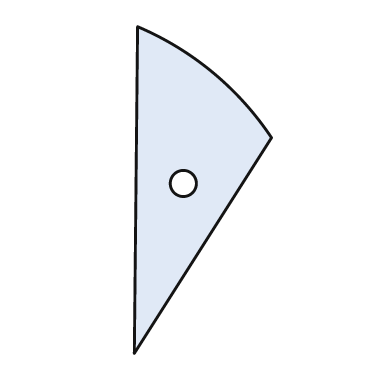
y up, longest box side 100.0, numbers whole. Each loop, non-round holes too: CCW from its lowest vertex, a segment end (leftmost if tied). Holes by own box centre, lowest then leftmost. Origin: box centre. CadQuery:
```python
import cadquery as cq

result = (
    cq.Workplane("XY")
    .moveTo(-21.0, -50.0)
    .lineTo(21.0, 16.0)
    .threePointArc((3.0, 36.0), (-20.0, 50.0))
    .close()
    .moveTo(-6.0, 2.0)
    .circle(4.0)
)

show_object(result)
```